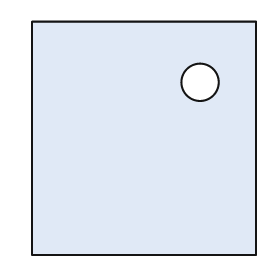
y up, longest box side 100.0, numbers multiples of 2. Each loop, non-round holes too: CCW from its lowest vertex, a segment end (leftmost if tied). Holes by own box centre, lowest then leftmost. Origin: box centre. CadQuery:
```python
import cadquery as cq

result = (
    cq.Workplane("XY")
    .moveTo(-48.0, -50.0)
    .lineTo(48.0, -50.0)
    .lineTo(48.0, 50.0)
    .lineTo(-48.0, 50.0)
    .close()
    .moveTo(24.0, 24.0)
    .circle(8.0)
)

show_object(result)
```